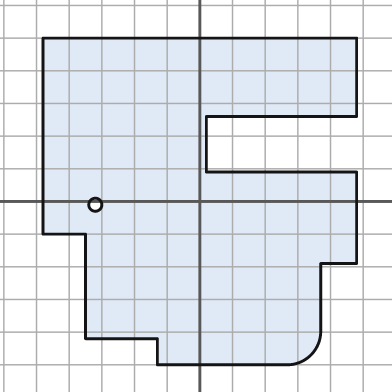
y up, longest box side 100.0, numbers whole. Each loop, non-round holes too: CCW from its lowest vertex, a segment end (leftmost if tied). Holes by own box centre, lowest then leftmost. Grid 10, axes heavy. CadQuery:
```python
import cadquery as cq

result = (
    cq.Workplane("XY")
    .moveTo(-13.0, -50.0)
    .lineTo(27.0, -50.0)
    .threePointArc((34.0, -47.0), (37.0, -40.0))
    .lineTo(37.0, -19.0)
    .lineTo(48.0, -19.0)
    .lineTo(48.0, 9.0)
    .lineTo(2.0, 9.0)
    .lineTo(2.0, 26.0)
    .lineTo(48.0, 26.0)
    .lineTo(48.0, 50.0)
    .lineTo(-48.0, 50.0)
    .lineTo(-48.0, -10.0)
    .lineTo(-35.0, -10.0)
    .lineTo(-35.0, -42.0)
    .lineTo(-13.0, -42.0)
    .close()
    .moveTo(-32.0, -1.0)
    .circle(2.0)
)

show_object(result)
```